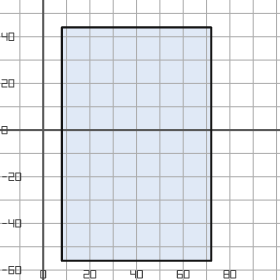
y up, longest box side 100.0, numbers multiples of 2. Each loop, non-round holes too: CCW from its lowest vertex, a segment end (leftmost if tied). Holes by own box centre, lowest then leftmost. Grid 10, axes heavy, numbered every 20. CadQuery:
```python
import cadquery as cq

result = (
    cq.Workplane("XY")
    .moveTo(8.0, -56.0)
    .lineTo(72.0, -56.0)
    .lineTo(72.0, 44.0)
    .lineTo(8.0, 44.0)
    .close()
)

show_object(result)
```